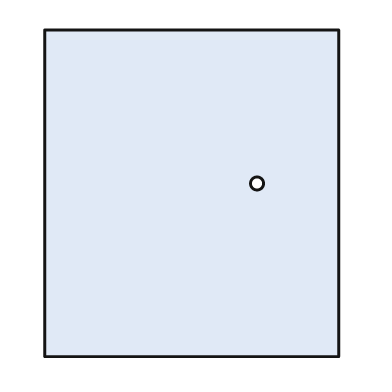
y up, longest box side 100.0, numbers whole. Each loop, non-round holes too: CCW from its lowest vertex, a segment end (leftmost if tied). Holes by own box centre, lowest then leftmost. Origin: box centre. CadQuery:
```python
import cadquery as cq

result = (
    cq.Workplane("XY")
    .moveTo(-45.0, -50.0)
    .lineTo(45.0, -50.0)
    .lineTo(45.0, 50.0)
    .lineTo(-45.0, 50.0)
    .close()
    .moveTo(20.0, 3.0)
    .circle(2.0)
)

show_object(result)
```